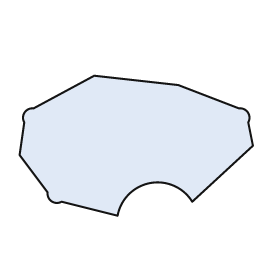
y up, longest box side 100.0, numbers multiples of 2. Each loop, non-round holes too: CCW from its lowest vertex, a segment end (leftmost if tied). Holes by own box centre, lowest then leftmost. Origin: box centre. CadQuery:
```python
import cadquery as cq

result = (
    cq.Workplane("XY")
    .moveTo(-8.0, -30.0)
    .threePointArc((6.0, -16.0), (24.0, -24.0))
    .lineTo(50.0, 0.0)
    .lineTo(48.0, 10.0)
    .threePointArc((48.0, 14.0), (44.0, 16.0))
    .lineTo(18.0, 26.0)
    .lineTo(-18.0, 30.0)
    .lineTo(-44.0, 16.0)
    .threePointArc((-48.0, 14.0), (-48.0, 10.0))
    .lineTo(-50.0, -4.0)
    .lineTo(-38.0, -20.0)
    .threePointArc((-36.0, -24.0), (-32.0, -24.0))
    .close()
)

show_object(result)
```